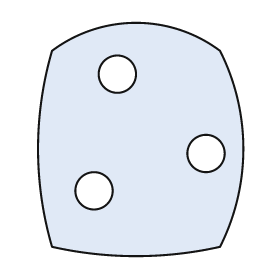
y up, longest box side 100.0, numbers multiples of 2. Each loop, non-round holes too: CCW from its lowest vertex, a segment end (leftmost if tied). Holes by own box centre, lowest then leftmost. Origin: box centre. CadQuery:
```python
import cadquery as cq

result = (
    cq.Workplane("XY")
    .moveTo(-38.0, -46.0)
    .threePointArc((-2.0, -50.0), (34.0, -46.0))
    .threePointArc((44.0, -4.0), (34.0, 38.0))
    .threePointArc((-2.0, 50.0), (-38.0, 38.0))
    .threePointArc((-44.0, -4.0), (-38.0, -46.0))
    .close()
    .moveTo(-20.0, -22.0)
    .circle(8.0)
    .moveTo(28.0, -6.0)
    .circle(8.0)
    .moveTo(-10.0, 28.0)
    .circle(8.0)
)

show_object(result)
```